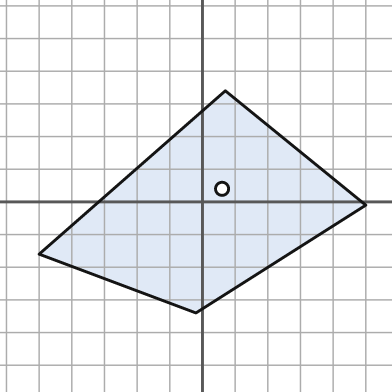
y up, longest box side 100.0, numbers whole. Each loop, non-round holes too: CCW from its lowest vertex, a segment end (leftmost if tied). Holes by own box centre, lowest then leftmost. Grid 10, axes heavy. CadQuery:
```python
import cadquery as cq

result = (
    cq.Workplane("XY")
    .moveTo(-2.0, -34.0)
    .lineTo(50.0, -1.0)
    .lineTo(7.0, 34.0)
    .lineTo(-50.0, -16.0)
    .close()
    .moveTo(6.0, 4.0)
    .circle(2.0)
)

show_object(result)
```